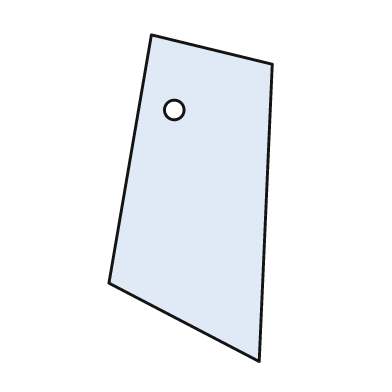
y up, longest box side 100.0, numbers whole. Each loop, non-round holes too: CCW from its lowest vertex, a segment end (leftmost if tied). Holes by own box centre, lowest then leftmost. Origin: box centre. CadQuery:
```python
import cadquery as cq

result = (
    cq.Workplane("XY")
    .moveTo(21.0, -50.0)
    .lineTo(25.0, 41.0)
    .lineTo(-12.0, 50.0)
    .lineTo(-25.0, -26.0)
    .close()
    .moveTo(-5.0, 27.0)
    .circle(3.0)
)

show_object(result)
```